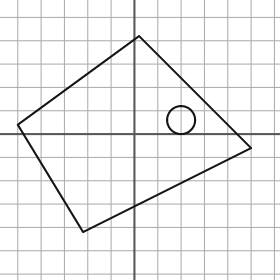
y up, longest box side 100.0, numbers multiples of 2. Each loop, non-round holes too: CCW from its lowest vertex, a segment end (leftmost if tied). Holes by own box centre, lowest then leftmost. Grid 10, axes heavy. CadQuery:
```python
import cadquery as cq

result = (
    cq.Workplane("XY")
    .moveTo(-22.0, -42.0)
    .lineTo(50.0, -6.0)
    .lineTo(2.0, 42.0)
    .lineTo(-50.0, 4.0)
    .close()
    .moveTo(20.0, 6.0)
    .circle(6.0)
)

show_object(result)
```